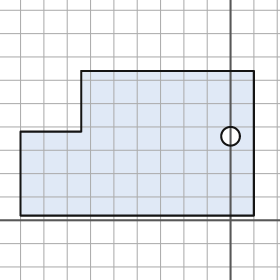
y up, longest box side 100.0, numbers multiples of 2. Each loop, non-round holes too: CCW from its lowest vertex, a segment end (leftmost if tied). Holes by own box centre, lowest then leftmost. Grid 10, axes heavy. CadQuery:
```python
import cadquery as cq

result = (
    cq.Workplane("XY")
    .moveTo(-90.0, 2.0)
    .lineTo(10.0, 2.0)
    .lineTo(10.0, 64.0)
    .lineTo(-64.0, 64.0)
    .lineTo(-64.0, 38.0)
    .lineTo(-90.0, 38.0)
    .close()
    .moveTo(0.0, 36.0)
    .circle(4.0)
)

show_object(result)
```